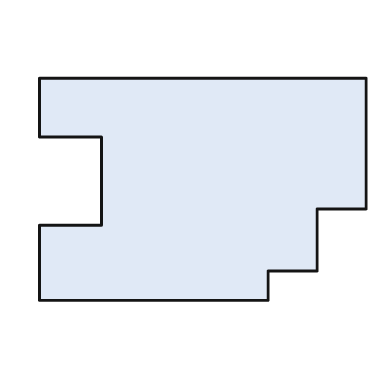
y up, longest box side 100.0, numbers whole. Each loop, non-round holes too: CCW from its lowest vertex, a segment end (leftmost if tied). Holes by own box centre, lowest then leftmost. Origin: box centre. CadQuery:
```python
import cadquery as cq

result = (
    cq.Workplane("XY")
    .moveTo(-50.0, -34.0)
    .lineTo(20.0, -34.0)
    .lineTo(20.0, -25.0)
    .lineTo(35.0, -25.0)
    .lineTo(35.0, -6.0)
    .lineTo(50.0, -6.0)
    .lineTo(50.0, 34.0)
    .lineTo(-50.0, 34.0)
    .lineTo(-50.0, 16.0)
    .lineTo(-31.0, 16.0)
    .lineTo(-31.0, -11.0)
    .lineTo(-50.0, -11.0)
    .close()
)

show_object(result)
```